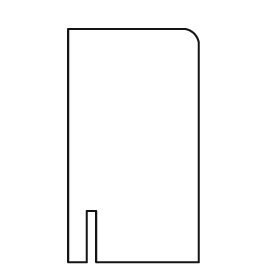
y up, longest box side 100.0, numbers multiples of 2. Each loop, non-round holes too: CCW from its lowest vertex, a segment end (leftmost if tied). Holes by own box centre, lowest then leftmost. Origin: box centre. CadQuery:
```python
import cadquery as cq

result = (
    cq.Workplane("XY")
    .moveTo(-28.0, -50.0)
    .lineTo(-20.0, -50.0)
    .lineTo(-20.0, -28.0)
    .lineTo(-16.0, -28.0)
    .lineTo(-16.0, -50.0)
    .lineTo(28.0, -50.0)
    .lineTo(28.0, 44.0)
    .threePointArc((26.0, 48.0), (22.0, 50.0))
    .lineTo(-28.0, 50.0)
    .close()
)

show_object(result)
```